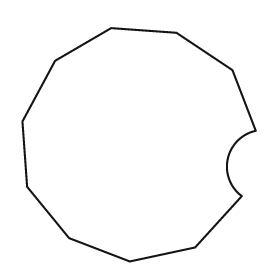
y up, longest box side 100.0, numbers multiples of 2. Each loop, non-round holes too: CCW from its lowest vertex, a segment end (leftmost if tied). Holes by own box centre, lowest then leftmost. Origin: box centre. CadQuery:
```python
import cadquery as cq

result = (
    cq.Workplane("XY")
    .moveTo(-4.0, -50.0)
    .lineTo(24.0, -44.0)
    .lineTo(44.0, -22.0)
    .threePointArc((38.0, -6.0), (50.0, 6.0))
    .lineTo(40.0, 32.0)
    .lineTo(16.0, 48.0)
    .lineTo(-12.0, 50.0)
    .lineTo(-36.0, 36.0)
    .lineTo(-50.0, 10.0)
    .lineTo(-48.0, -18.0)
    .lineTo(-30.0, -40.0)
    .close()
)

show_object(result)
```